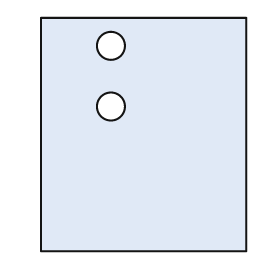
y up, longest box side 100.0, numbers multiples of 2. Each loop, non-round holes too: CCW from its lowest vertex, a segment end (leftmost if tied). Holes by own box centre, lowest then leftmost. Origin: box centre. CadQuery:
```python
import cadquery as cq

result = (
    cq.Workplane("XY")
    .moveTo(-44.0, -50.0)
    .lineTo(44.0, -50.0)
    .lineTo(44.0, 50.0)
    .lineTo(-44.0, 50.0)
    .close()
    .moveTo(-14.0, 12.0)
    .circle(6.0)
    .moveTo(-14.0, 38.0)
    .circle(6.0)
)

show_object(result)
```